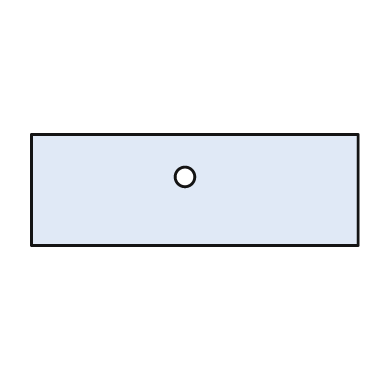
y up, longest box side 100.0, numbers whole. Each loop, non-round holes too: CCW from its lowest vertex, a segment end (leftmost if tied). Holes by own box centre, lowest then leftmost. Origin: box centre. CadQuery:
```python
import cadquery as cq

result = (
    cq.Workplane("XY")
    .moveTo(-50.0, -17.0)
    .lineTo(50.0, -17.0)
    .lineTo(50.0, 17.0)
    .lineTo(-50.0, 17.0)
    .close()
    .moveTo(-3.0, 4.0)
    .circle(3.0)
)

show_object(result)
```